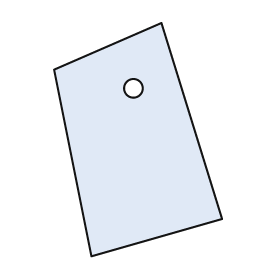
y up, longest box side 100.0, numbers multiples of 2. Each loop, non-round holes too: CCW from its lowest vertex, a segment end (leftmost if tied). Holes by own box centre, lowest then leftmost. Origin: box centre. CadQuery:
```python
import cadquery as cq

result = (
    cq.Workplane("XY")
    .moveTo(-20.0, -50.0)
    .lineTo(36.0, -34.0)
    .lineTo(10.0, 50.0)
    .lineTo(-36.0, 30.0)
    .close()
    .moveTo(-2.0, 22.0)
    .circle(4.0)
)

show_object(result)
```